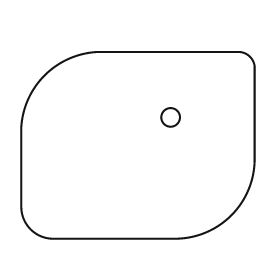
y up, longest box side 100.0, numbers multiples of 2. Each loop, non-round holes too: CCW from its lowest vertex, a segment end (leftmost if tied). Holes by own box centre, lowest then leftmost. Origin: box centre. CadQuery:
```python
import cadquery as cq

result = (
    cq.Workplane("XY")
    .moveTo(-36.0, -40.0)
    .lineTo(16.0, -40.0)
    .threePointArc((40.0, -30.0), (50.0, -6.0))
    .lineTo(50.0, 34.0)
    .threePointArc((48.0, 38.0), (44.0, 40.0))
    .lineTo(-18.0, 40.0)
    .threePointArc((-40.0, 30.0), (-50.0, 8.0))
    .lineTo(-50.0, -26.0)
    .threePointArc((-46.0, -36.0), (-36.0, -40.0))
    .close()
    .moveTo(14.0, 12.0)
    .circle(4.0)
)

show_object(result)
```